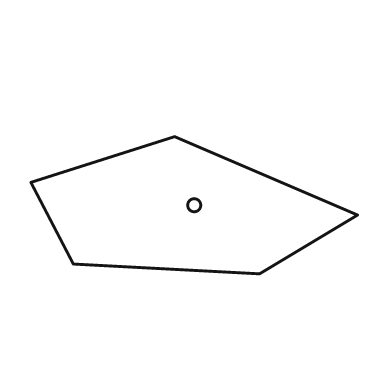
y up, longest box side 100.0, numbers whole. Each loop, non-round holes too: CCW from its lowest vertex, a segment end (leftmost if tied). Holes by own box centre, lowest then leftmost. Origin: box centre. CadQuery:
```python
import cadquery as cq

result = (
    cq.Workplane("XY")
    .moveTo(20.0, -21.0)
    .lineTo(50.0, -3.0)
    .lineTo(-6.0, 21.0)
    .lineTo(-50.0, 7.0)
    .lineTo(-37.0, -18.0)
    .close()
    .moveTo(0.0, 0.0)
    .circle(2.0)
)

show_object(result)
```